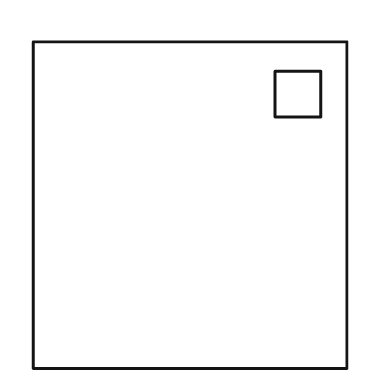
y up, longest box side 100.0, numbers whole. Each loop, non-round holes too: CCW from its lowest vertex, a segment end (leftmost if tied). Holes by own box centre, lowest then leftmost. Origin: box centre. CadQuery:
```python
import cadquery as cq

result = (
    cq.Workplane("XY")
    .moveTo(-48.0, -50.0)
    .lineTo(48.0, -50.0)
    .lineTo(48.0, 50.0)
    .lineTo(-48.0, 50.0)
    .close()
    .moveTo(26.0, 27.0)
    .lineTo(40.0, 27.0)
    .lineTo(40.0, 41.0)
    .lineTo(26.0, 41.0)
    .close()
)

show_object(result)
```